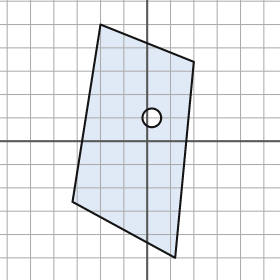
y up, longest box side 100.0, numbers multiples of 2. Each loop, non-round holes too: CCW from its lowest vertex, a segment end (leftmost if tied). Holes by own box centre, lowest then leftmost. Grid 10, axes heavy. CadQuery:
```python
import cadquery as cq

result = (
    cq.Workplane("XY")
    .moveTo(12.0, -50.0)
    .lineTo(20.0, 34.0)
    .lineTo(-20.0, 50.0)
    .lineTo(-32.0, -26.0)
    .close()
    .moveTo(2.0, 10.0)
    .circle(4.0)
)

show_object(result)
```